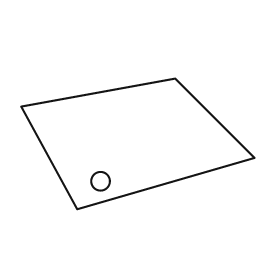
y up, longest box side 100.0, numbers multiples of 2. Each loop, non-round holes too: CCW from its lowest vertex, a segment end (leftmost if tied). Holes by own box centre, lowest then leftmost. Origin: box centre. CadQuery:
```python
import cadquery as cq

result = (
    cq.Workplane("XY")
    .moveTo(-26.0, -28.0)
    .lineTo(50.0, -6.0)
    .lineTo(16.0, 28.0)
    .lineTo(-50.0, 16.0)
    .close()
    .moveTo(-16.0, -16.0)
    .circle(4.0)
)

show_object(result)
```